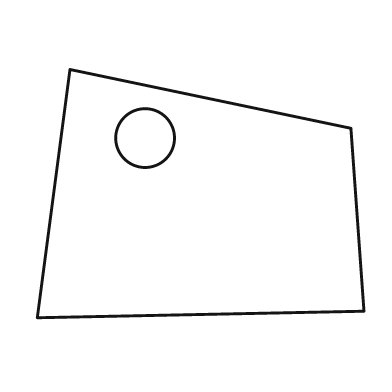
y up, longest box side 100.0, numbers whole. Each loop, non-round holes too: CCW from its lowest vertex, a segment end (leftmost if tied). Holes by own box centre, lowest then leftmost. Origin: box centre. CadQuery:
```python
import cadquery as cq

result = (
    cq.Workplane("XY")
    .moveTo(-50.0, -38.0)
    .lineTo(50.0, -36.0)
    .lineTo(46.0, 20.0)
    .lineTo(-40.0, 38.0)
    .close()
    .moveTo(-17.0, 17.0)
    .circle(9.0)
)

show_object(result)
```